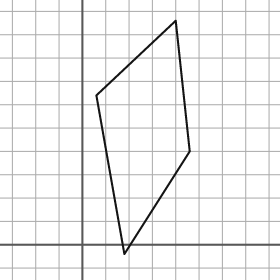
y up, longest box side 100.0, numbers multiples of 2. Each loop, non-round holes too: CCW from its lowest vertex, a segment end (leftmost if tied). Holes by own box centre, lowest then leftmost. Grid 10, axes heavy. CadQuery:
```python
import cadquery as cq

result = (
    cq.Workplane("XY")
    .moveTo(18.0, -4.0)
    .lineTo(46.0, 40.0)
    .lineTo(40.0, 96.0)
    .lineTo(6.0, 64.0)
    .close()
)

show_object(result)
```